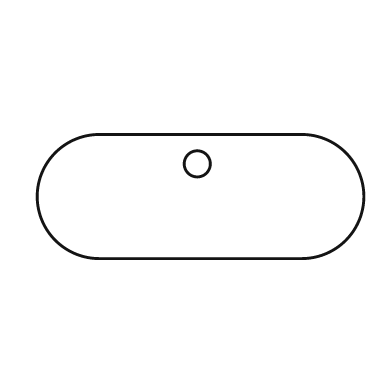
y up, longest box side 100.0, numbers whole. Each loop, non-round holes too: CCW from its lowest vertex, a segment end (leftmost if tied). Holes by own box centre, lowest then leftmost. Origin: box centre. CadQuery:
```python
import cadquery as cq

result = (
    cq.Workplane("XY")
    .moveTo(-31.0, -19.0)
    .lineTo(31.0, -19.0)
    .threePointArc((50.0, 0.0), (31.0, 19.0))
    .lineTo(-31.0, 19.0)
    .threePointArc((-50.0, 0.0), (-31.0, -19.0))
    .close()
    .moveTo(-1.0, 10.0)
    .circle(4.0)
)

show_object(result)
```